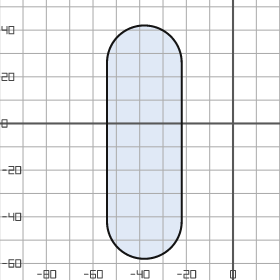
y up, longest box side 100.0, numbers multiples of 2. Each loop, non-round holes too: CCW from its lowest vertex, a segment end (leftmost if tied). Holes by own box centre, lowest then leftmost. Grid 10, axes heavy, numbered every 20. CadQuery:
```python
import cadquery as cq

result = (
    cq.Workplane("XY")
    .moveTo(-54.0, -42.0)
    .threePointArc((-38.0, -58.0), (-22.0, -42.0))
    .lineTo(-22.0, 26.0)
    .threePointArc((-38.0, 42.0), (-54.0, 26.0))
    .close()
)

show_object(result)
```